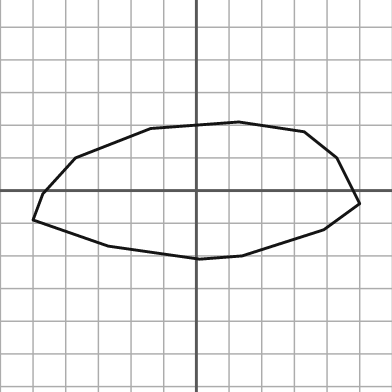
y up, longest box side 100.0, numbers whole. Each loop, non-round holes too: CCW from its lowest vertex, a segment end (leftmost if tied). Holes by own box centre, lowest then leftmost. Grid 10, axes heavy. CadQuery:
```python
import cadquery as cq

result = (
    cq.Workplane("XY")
    .moveTo(1.0, -21.0)
    .lineTo(14.0, -20.0)
    .lineTo(39.0, -12.0)
    .lineTo(50.0, -4.0)
    .lineTo(43.0, 10.0)
    .lineTo(33.0, 18.0)
    .lineTo(13.0, 21.0)
    .lineTo(-14.0, 19.0)
    .lineTo(-37.0, 10.0)
    .lineTo(-47.0, -1.0)
    .lineTo(-50.0, -9.0)
    .lineTo(-27.0, -17.0)
    .close()
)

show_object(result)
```